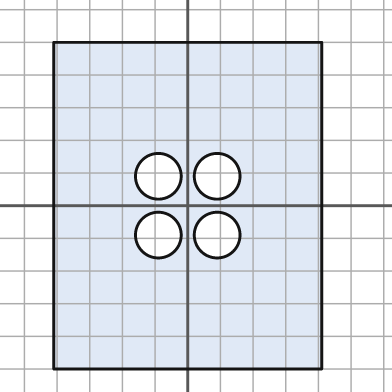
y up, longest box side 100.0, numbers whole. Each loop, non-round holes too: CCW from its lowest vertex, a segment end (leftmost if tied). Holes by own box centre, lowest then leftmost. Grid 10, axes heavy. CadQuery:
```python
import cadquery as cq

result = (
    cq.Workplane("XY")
    .moveTo(-41.0, -50.0)
    .lineTo(41.0, -50.0)
    .lineTo(41.0, 50.0)
    .lineTo(-41.0, 50.0)
    .close()
    .moveTo(-9.0, -9.0)
    .circle(7.0)
    .moveTo(9.0, -9.0)
    .circle(7.0)
    .moveTo(-9.0, 9.0)
    .circle(7.0)
    .moveTo(9.0, 9.0)
    .circle(7.0)
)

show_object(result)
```